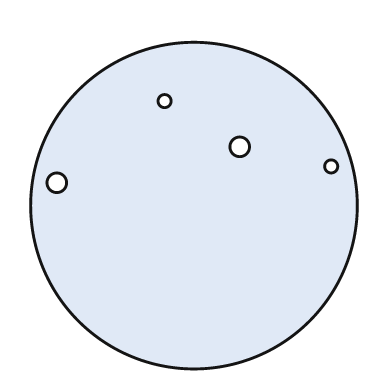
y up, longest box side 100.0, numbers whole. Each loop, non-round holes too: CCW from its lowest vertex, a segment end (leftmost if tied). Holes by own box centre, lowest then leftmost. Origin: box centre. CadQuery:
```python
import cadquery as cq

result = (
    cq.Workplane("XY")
    .moveTo(0.0, 0.0)
    .circle(50.0)
    .moveTo(-42.0, 7.0)
    .circle(3.0)
    .moveTo(42.0, 12.0)
    .circle(2.0)
    .moveTo(14.0, 18.0)
    .circle(3.0)
    .moveTo(-9.0, 32.0)
    .circle(2.0)
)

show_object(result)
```